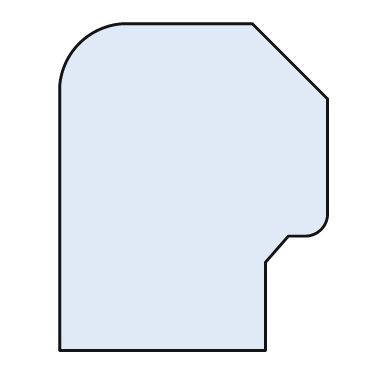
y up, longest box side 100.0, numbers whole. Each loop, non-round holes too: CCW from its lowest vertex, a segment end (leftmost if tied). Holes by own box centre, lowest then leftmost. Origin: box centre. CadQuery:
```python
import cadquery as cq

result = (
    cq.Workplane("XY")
    .moveTo(-41.0, -50.0)
    .lineTo(22.0, -50.0)
    .lineTo(22.0, -23.0)
    .lineTo(29.0, -15.0)
    .lineTo(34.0, -15.0)
    .threePointArc((39.0, -13.0), (41.0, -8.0))
    .lineTo(41.0, 27.0)
    .lineTo(18.0, 50.0)
    .lineTo(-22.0, 50.0)
    .threePointArc((-35.0, 44.0), (-41.0, 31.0))
    .close()
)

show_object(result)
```